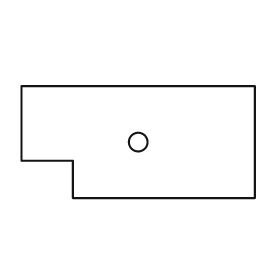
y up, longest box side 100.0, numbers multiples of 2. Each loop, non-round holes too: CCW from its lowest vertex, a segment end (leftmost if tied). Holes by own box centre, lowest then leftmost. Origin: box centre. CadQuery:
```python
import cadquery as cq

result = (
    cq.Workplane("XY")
    .moveTo(-28.0, -24.0)
    .lineTo(50.0, -24.0)
    .lineTo(50.0, 24.0)
    .lineTo(-50.0, 24.0)
    .lineTo(-50.0, -8.0)
    .lineTo(-28.0, -8.0)
    .close()
    .moveTo(0.0, 0.0)
    .circle(4.0)
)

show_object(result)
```